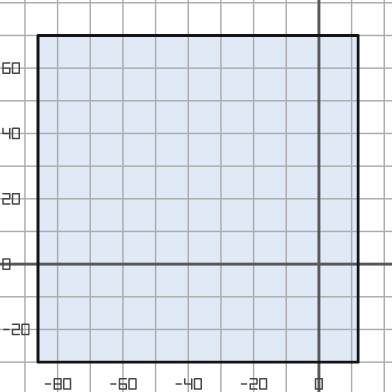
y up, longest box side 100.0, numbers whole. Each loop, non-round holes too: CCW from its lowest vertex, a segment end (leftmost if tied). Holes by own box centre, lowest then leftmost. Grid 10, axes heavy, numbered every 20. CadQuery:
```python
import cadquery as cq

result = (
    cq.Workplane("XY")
    .moveTo(-86.0, -30.0)
    .lineTo(12.0, -30.0)
    .lineTo(12.0, 70.0)
    .lineTo(-86.0, 70.0)
    .close()
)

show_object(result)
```